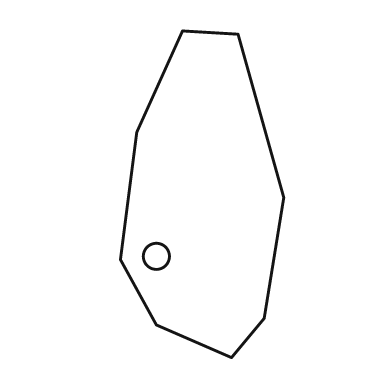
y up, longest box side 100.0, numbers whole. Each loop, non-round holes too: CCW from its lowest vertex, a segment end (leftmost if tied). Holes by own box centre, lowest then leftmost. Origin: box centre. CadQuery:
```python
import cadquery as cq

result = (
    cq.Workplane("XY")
    .moveTo(9.0, -50.0)
    .lineTo(19.0, -38.0)
    .lineTo(25.0, -1.0)
    .lineTo(11.0, 49.0)
    .lineTo(-6.0, 50.0)
    .lineTo(-20.0, 19.0)
    .lineTo(-25.0, -20.0)
    .lineTo(-14.0, -40.0)
    .close()
    .moveTo(-14.0, -19.0)
    .circle(4.0)
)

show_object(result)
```